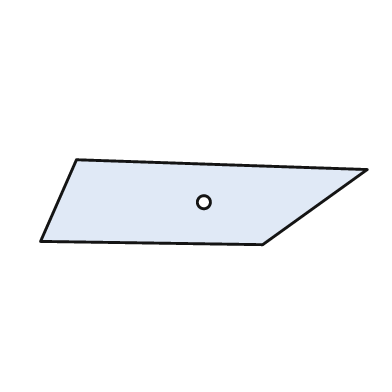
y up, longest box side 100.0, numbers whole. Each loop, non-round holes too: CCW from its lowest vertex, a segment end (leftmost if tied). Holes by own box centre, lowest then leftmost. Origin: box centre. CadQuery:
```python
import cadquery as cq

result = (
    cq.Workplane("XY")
    .moveTo(18.0, -13.0)
    .lineTo(50.0, 10.0)
    .lineTo(-39.0, 13.0)
    .lineTo(-50.0, -12.0)
    .close()
    .moveTo(0.0, 0.0)
    .circle(2.0)
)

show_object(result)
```